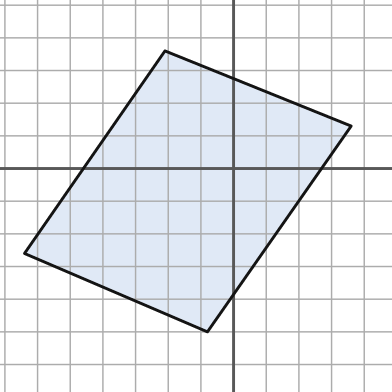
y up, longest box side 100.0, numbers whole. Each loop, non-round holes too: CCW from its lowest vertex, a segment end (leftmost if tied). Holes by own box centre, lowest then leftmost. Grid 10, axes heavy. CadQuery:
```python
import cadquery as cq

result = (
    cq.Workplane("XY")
    .moveTo(-8.0, -50.0)
    .lineTo(36.0, 13.0)
    .lineTo(-21.0, 36.0)
    .lineTo(-64.0, -26.0)
    .close()
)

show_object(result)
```